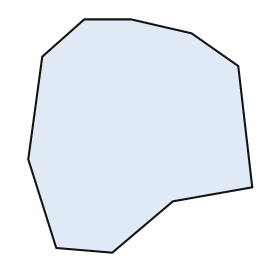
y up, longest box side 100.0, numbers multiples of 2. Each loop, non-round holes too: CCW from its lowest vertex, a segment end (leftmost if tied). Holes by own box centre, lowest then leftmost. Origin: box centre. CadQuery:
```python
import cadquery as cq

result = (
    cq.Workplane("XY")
    .moveTo(-12.0, -50.0)
    .lineTo(14.0, -28.0)
    .lineTo(48.0, -22.0)
    .lineTo(42.0, 30.0)
    .lineTo(22.0, 44.0)
    .lineTo(-4.0, 50.0)
    .lineTo(-24.0, 50.0)
    .lineTo(-42.0, 34.0)
    .lineTo(-48.0, -10.0)
    .lineTo(-36.0, -48.0)
    .close()
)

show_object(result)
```